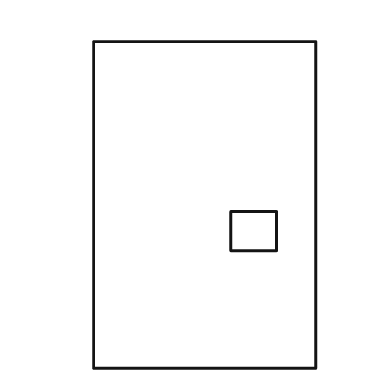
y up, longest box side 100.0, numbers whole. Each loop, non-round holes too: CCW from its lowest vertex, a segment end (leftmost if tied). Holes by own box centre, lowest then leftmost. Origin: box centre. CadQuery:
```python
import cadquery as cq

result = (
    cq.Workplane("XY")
    .moveTo(-34.0, -50.0)
    .lineTo(34.0, -50.0)
    .lineTo(34.0, 50.0)
    .lineTo(-34.0, 50.0)
    .close()
    .moveTo(8.0, -14.0)
    .lineTo(22.0, -14.0)
    .lineTo(22.0, -2.0)
    .lineTo(8.0, -2.0)
    .close()
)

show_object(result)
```